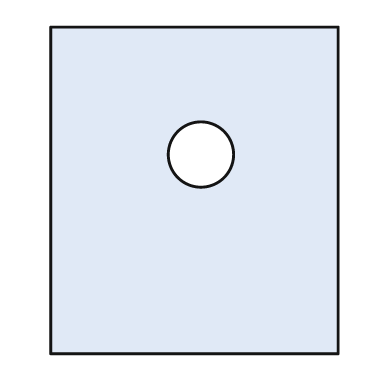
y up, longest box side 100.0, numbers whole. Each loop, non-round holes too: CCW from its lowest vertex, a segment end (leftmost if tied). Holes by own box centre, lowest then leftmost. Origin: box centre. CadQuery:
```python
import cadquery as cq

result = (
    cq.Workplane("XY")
    .moveTo(-44.0, -50.0)
    .lineTo(44.0, -50.0)
    .lineTo(44.0, 50.0)
    .lineTo(-44.0, 50.0)
    .close()
    .moveTo(2.0, 11.0)
    .circle(10.0)
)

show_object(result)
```